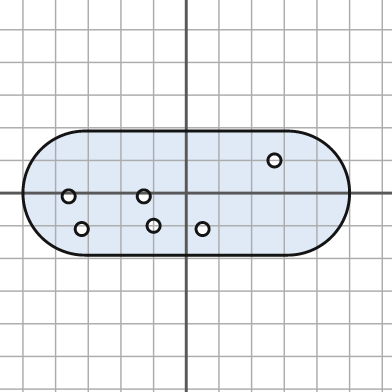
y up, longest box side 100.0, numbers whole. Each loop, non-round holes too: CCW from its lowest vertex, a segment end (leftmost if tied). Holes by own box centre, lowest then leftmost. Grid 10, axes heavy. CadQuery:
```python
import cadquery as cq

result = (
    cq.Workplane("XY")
    .moveTo(-31.0, -19.0)
    .lineTo(31.0, -19.0)
    .threePointArc((50.0, 0.0), (31.0, 19.0))
    .lineTo(-31.0, 19.0)
    .threePointArc((-50.0, 0.0), (-31.0, -19.0))
    .close()
    .moveTo(-32.0, -11.0)
    .circle(2.0)
    .moveTo(5.0, -11.0)
    .circle(2.0)
    .moveTo(-10.0, -10.0)
    .circle(2.0)
    .moveTo(-36.0, -1.0)
    .circle(2.0)
    .moveTo(-13.0, -1.0)
    .circle(2.0)
    .moveTo(27.0, 10.0)
    .circle(2.0)
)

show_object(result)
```